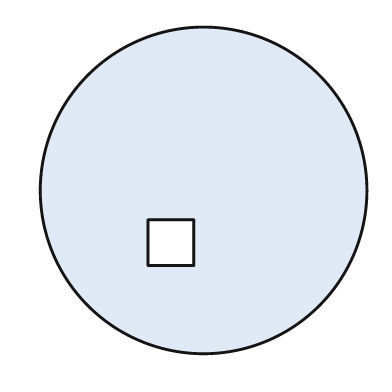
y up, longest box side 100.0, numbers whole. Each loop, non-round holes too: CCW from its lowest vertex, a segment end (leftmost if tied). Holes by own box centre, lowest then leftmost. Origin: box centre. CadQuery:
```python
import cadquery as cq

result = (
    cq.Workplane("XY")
    .moveTo(0.0, 0.0)
    .circle(50.0)
    .moveTo(-17.0, -23.0)
    .lineTo(-3.0, -23.0)
    .lineTo(-3.0, -9.0)
    .lineTo(-17.0, -9.0)
    .close()
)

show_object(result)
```